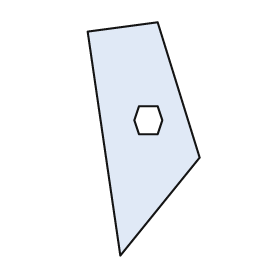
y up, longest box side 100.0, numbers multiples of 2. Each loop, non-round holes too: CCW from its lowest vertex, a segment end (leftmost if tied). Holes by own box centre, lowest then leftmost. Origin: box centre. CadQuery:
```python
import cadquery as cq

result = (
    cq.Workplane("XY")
    .moveTo(-10.0, -50.0)
    .lineTo(24.0, -8.0)
    .lineTo(6.0, 50.0)
    .lineTo(-24.0, 46.0)
    .close()
    .moveTo(-2.0, 2.0)
    .lineTo(6.0, 2.0)
    .lineTo(8.0, 8.0)
    .lineTo(6.0, 14.0)
    .lineTo(-2.0, 14.0)
    .lineTo(-4.0, 8.0)
    .close()
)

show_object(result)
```